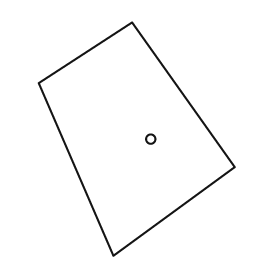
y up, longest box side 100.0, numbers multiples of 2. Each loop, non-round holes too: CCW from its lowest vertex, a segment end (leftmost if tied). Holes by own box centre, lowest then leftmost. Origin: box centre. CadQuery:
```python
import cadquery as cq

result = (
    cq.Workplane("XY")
    .moveTo(-10.0, -50.0)
    .lineTo(42.0, -12.0)
    .lineTo(-2.0, 50.0)
    .lineTo(-42.0, 24.0)
    .close()
    .moveTo(6.0, 0.0)
    .circle(2.0)
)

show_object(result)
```